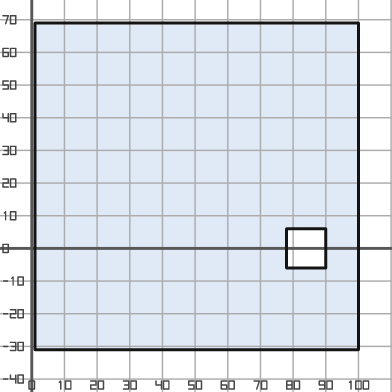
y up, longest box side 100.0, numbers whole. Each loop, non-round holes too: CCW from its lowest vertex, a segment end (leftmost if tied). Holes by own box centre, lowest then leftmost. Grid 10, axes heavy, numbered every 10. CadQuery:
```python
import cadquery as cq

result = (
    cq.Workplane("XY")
    .moveTo(1.0, -31.0)
    .lineTo(100.0, -31.0)
    .lineTo(100.0, 69.0)
    .lineTo(1.0, 69.0)
    .close()
    .moveTo(78.0, -6.0)
    .lineTo(90.0, -6.0)
    .lineTo(90.0, 6.0)
    .lineTo(78.0, 6.0)
    .close()
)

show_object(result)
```